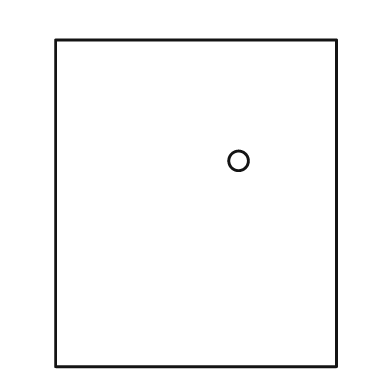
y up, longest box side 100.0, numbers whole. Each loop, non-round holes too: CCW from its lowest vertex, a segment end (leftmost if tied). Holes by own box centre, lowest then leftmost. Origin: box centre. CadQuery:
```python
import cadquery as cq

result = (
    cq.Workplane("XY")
    .moveTo(-43.0, -50.0)
    .lineTo(43.0, -50.0)
    .lineTo(43.0, 50.0)
    .lineTo(-43.0, 50.0)
    .close()
    .moveTo(13.0, 13.0)
    .circle(3.0)
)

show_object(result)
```